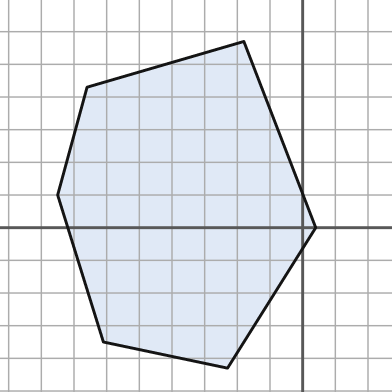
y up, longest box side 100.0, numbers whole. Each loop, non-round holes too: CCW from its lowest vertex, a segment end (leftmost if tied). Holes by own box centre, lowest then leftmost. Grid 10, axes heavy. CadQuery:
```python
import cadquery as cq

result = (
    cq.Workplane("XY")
    .moveTo(-23.0, -43.0)
    .lineTo(4.0, 0.0)
    .lineTo(-18.0, 57.0)
    .lineTo(-66.0, 43.0)
    .lineTo(-75.0, 10.0)
    .lineTo(-61.0, -35.0)
    .close()
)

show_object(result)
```